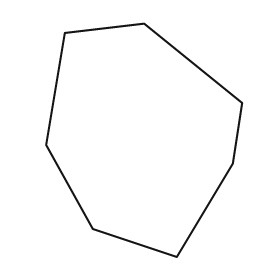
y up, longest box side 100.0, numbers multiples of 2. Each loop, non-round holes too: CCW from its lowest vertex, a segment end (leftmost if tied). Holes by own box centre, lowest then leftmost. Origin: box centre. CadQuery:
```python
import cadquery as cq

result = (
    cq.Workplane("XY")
    .moveTo(14.0, -50.0)
    .lineTo(38.0, -10.0)
    .lineTo(42.0, 16.0)
    .lineTo(0.0, 50.0)
    .lineTo(-34.0, 46.0)
    .lineTo(-42.0, -2.0)
    .lineTo(-22.0, -38.0)
    .close()
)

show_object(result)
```